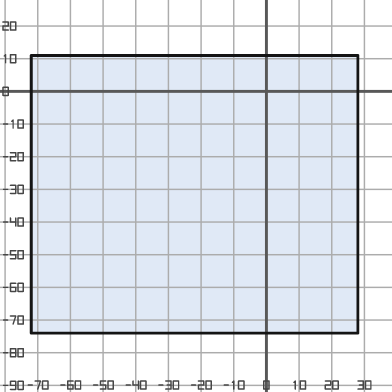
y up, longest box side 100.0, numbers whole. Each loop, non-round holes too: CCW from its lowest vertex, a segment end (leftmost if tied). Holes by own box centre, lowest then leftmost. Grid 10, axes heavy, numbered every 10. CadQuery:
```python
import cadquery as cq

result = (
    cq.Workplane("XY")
    .moveTo(-72.0, -74.0)
    .lineTo(28.0, -74.0)
    .lineTo(28.0, 11.0)
    .lineTo(-72.0, 11.0)
    .close()
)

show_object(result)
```